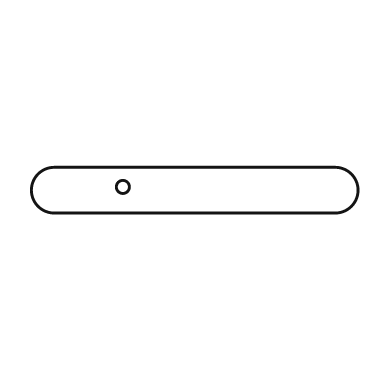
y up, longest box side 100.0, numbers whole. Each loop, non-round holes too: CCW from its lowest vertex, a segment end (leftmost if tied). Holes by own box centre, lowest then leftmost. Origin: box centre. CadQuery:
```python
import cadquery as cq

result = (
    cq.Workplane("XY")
    .moveTo(-43.0, -7.0)
    .lineTo(43.0, -7.0)
    .threePointArc((50.0, 0.0), (43.0, 7.0))
    .lineTo(-43.0, 7.0)
    .threePointArc((-50.0, 0.0), (-43.0, -7.0))
    .close()
    .moveTo(-22.0, 1.0)
    .circle(2.0)
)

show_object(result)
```